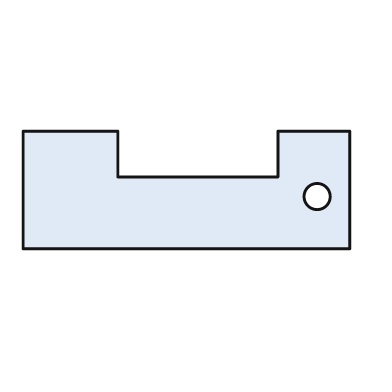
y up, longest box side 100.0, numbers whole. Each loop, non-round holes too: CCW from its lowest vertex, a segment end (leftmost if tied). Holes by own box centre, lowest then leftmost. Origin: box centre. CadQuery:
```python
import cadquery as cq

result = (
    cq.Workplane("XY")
    .moveTo(-50.0, -18.0)
    .lineTo(50.0, -18.0)
    .lineTo(50.0, 18.0)
    .lineTo(28.0, 18.0)
    .lineTo(28.0, 4.0)
    .lineTo(-21.0, 4.0)
    .lineTo(-21.0, 18.0)
    .lineTo(-50.0, 18.0)
    .close()
    .moveTo(40.0, -2.0)
    .circle(4.0)
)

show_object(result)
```